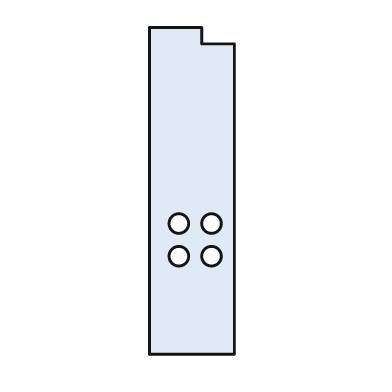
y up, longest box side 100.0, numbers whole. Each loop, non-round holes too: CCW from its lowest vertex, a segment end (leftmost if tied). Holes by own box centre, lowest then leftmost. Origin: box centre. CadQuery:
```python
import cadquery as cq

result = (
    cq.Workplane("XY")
    .moveTo(-13.0, -50.0)
    .lineTo(13.0, -50.0)
    .lineTo(13.0, 45.0)
    .lineTo(3.0, 45.0)
    .lineTo(3.0, 50.0)
    .lineTo(-13.0, 50.0)
    .close()
    .moveTo(-4.0, -20.0)
    .circle(3.0)
    .moveTo(6.0, -20.0)
    .circle(3.0)
    .moveTo(-4.0, -10.0)
    .circle(3.0)
    .moveTo(6.0, -10.0)
    .circle(3.0)
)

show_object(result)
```